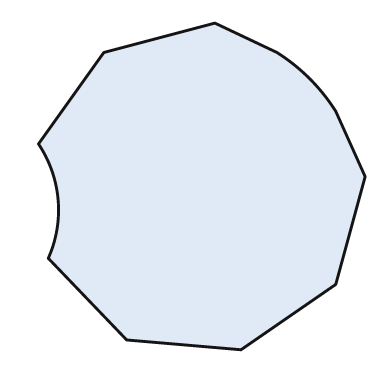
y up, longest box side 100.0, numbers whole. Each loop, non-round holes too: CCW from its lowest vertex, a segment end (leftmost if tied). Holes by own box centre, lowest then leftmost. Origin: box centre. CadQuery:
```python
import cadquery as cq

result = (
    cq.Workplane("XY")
    .moveTo(12.0, -50.0)
    .lineTo(41.0, -30.0)
    .lineTo(50.0, 3.0)
    .lineTo(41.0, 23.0)
    .threePointArc((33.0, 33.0), (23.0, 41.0))
    .lineTo(4.0, 50.0)
    .lineTo(-30.0, 41.0)
    .lineTo(-50.0, 13.0)
    .threePointArc((-44.0, -4.0), (-47.0, -22.0))
    .lineTo(-23.0, -47.0)
    .close()
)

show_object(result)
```